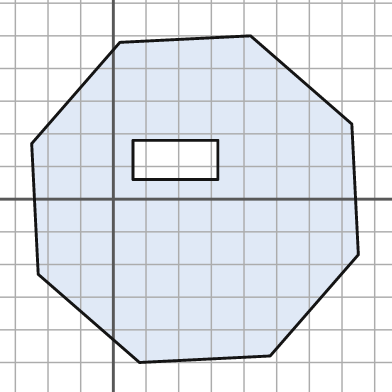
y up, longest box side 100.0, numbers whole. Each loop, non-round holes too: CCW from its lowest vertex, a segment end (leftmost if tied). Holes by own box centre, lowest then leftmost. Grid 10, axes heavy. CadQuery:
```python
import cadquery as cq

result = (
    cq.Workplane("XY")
    .moveTo(8.0, -50.0)
    .lineTo(48.0, -48.0)
    .lineTo(75.0, -17.0)
    .lineTo(73.0, 23.0)
    .lineTo(42.0, 50.0)
    .lineTo(2.0, 48.0)
    .lineTo(-25.0, 17.0)
    .lineTo(-23.0, -23.0)
    .close()
    .moveTo(6.0, 6.0)
    .lineTo(32.0, 6.0)
    .lineTo(32.0, 18.0)
    .lineTo(6.0, 18.0)
    .close()
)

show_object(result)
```